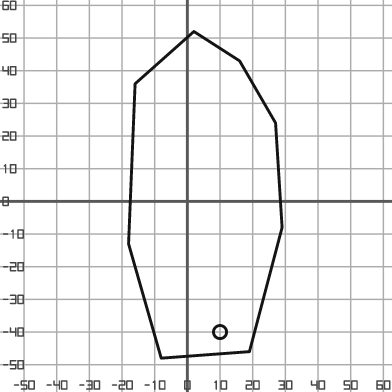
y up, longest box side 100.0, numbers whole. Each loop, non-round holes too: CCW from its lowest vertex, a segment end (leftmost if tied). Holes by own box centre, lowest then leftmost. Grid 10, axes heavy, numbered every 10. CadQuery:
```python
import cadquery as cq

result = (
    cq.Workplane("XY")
    .moveTo(-8.0, -48.0)
    .lineTo(19.0, -46.0)
    .lineTo(29.0, -8.0)
    .lineTo(27.0, 24.0)
    .lineTo(16.0, 43.0)
    .lineTo(2.0, 52.0)
    .lineTo(-16.0, 36.0)
    .lineTo(-18.0, -13.0)
    .close()
    .moveTo(10.0, -40.0)
    .circle(2.0)
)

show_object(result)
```